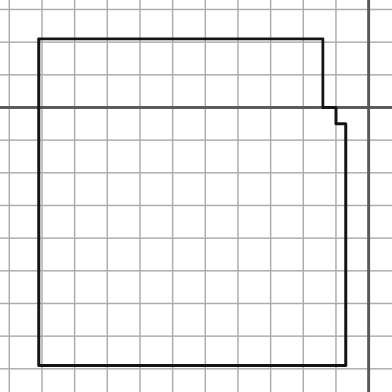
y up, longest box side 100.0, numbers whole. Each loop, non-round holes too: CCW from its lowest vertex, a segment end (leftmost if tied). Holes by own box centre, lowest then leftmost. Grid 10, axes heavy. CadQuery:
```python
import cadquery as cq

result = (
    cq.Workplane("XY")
    .moveTo(-101.0, -79.0)
    .lineTo(-7.0, -79.0)
    .lineTo(-7.0, -5.0)
    .lineTo(-10.0, -5.0)
    .lineTo(-10.0, 0.0)
    .lineTo(-14.0, 0.0)
    .lineTo(-14.0, 21.0)
    .lineTo(-101.0, 21.0)
    .close()
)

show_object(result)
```